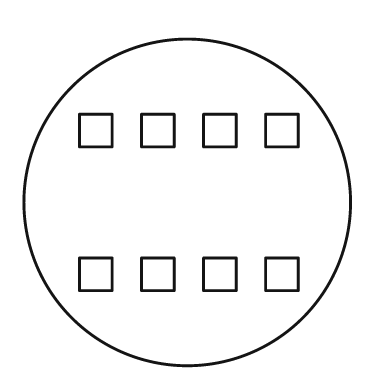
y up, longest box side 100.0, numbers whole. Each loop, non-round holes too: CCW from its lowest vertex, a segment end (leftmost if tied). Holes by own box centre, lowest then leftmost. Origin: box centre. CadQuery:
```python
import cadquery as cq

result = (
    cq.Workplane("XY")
    .moveTo(0.0, 0.0)
    .circle(50.0)
    .moveTo(-33.0, -27.0)
    .lineTo(-23.0, -27.0)
    .lineTo(-23.0, -17.0)
    .lineTo(-33.0, -17.0)
    .close()
    .moveTo(-14.0, -27.0)
    .lineTo(-4.0, -27.0)
    .lineTo(-4.0, -17.0)
    .lineTo(-14.0, -17.0)
    .close()
    .moveTo(5.0, -27.0)
    .lineTo(15.0, -27.0)
    .lineTo(15.0, -17.0)
    .lineTo(5.0, -17.0)
    .close()
    .moveTo(24.0, -27.0)
    .lineTo(34.0, -27.0)
    .lineTo(34.0, -17.0)
    .lineTo(24.0, -17.0)
    .close()
    .moveTo(-33.0, 17.0)
    .lineTo(-23.0, 17.0)
    .lineTo(-23.0, 27.0)
    .lineTo(-33.0, 27.0)
    .close()
    .moveTo(-14.0, 17.0)
    .lineTo(-4.0, 17.0)
    .lineTo(-4.0, 27.0)
    .lineTo(-14.0, 27.0)
    .close()
    .moveTo(5.0, 17.0)
    .lineTo(15.0, 17.0)
    .lineTo(15.0, 27.0)
    .lineTo(5.0, 27.0)
    .close()
    .moveTo(24.0, 17.0)
    .lineTo(34.0, 17.0)
    .lineTo(34.0, 27.0)
    .lineTo(24.0, 27.0)
    .close()
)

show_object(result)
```